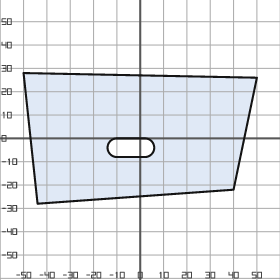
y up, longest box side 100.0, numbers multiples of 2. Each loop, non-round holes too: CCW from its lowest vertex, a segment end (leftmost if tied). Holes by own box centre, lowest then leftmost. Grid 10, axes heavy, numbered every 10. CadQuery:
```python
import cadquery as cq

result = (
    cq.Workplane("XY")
    .moveTo(-44.0, -28.0)
    .lineTo(40.0, -22.0)
    .lineTo(50.0, 26.0)
    .lineTo(-50.0, 28.0)
    .close()
    .moveTo(-10.0, -8.0)
    .lineTo(2.0, -8.0)
    .threePointArc((6.0, -4.0), (2.0, 0.0))
    .lineTo(-10.0, 0.0)
    .threePointArc((-14.0, -4.0), (-10.0, -8.0))
    .close()
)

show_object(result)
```